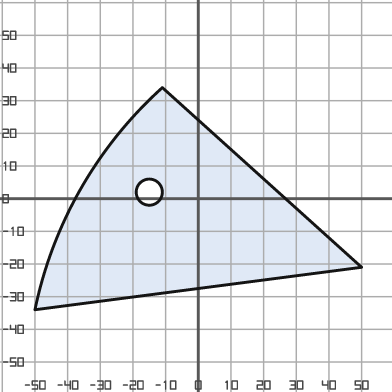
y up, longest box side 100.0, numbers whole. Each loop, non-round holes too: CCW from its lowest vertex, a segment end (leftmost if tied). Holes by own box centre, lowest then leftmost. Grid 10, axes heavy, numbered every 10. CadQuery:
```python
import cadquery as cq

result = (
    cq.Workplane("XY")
    .moveTo(-50.0, -34.0)
    .lineTo(50.0, -21.0)
    .lineTo(-11.0, 34.0)
    .threePointArc((-36.0, 3.0), (-50.0, -34.0))
    .close()
    .moveTo(-15.0, 2.0)
    .circle(4.0)
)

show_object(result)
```